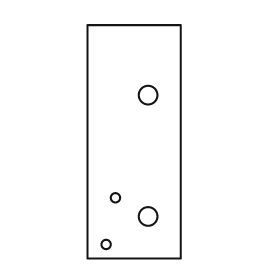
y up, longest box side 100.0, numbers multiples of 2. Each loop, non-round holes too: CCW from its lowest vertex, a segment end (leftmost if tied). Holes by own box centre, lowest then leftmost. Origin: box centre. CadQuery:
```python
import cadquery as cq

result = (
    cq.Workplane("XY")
    .moveTo(-20.0, -50.0)
    .lineTo(20.0, -50.0)
    .lineTo(20.0, 50.0)
    .lineTo(-20.0, 50.0)
    .close()
    .moveTo(-12.0, -44.0)
    .circle(2.0)
    .moveTo(6.0, -32.0)
    .circle(4.0)
    .moveTo(-8.0, -24.0)
    .circle(2.0)
    .moveTo(6.0, 20.0)
    .circle(4.0)
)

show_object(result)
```